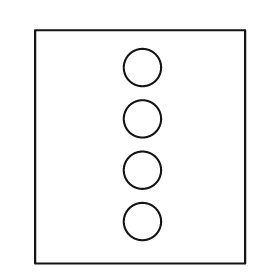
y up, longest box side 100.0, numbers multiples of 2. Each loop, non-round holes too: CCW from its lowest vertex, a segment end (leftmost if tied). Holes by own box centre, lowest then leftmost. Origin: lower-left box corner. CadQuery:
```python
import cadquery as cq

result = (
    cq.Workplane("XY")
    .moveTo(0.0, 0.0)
    .lineTo(90.0, 0.0)
    .lineTo(90.0, 100.0)
    .lineTo(0.0, 100.0)
    .close()
    .moveTo(46.0, 18.0)
    .circle(8.0)
    .moveTo(46.0, 40.0)
    .circle(8.0)
    .moveTo(46.0, 62.0)
    .circle(8.0)
    .moveTo(46.0, 84.0)
    .circle(8.0)
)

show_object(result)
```